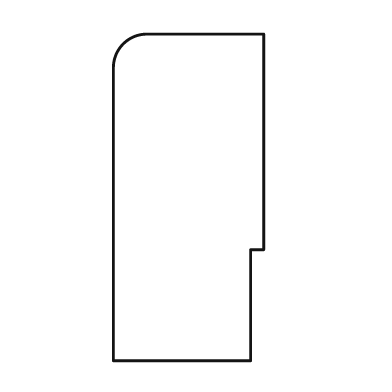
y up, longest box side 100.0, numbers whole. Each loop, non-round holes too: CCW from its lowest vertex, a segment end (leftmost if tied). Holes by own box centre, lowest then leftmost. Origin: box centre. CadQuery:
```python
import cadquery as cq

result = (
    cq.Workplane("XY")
    .moveTo(-23.0, -50.0)
    .lineTo(19.0, -50.0)
    .lineTo(19.0, -16.0)
    .lineTo(23.0, -16.0)
    .lineTo(23.0, 50.0)
    .lineTo(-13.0, 50.0)
    .threePointArc((-20.0, 47.0), (-23.0, 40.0))
    .close()
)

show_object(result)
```